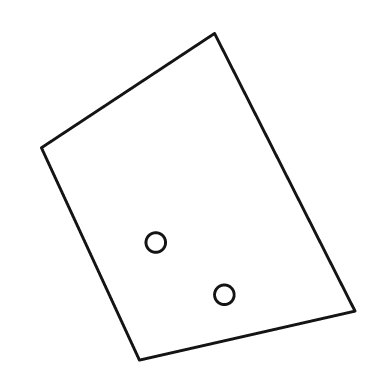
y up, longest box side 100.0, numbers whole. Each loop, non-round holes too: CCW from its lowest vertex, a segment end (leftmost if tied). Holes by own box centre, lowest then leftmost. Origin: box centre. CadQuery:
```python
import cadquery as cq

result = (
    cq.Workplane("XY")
    .moveTo(-18.0, -50.0)
    .lineTo(48.0, -35.0)
    .lineTo(5.0, 50.0)
    .lineTo(-48.0, 15.0)
    .close()
    .moveTo(8.0, -30.0)
    .circle(3.0)
    .moveTo(-13.0, -14.0)
    .circle(3.0)
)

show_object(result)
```